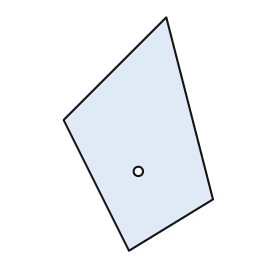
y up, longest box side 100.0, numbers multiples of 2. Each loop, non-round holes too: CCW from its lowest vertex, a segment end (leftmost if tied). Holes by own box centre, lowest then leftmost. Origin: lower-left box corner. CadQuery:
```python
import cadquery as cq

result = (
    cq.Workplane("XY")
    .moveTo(28.0, 0.0)
    .lineTo(64.0, 22.0)
    .lineTo(44.0, 100.0)
    .lineTo(0.0, 56.0)
    .close()
    .moveTo(32.0, 34.0)
    .circle(2.0)
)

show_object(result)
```